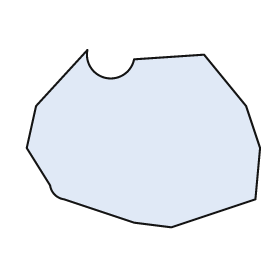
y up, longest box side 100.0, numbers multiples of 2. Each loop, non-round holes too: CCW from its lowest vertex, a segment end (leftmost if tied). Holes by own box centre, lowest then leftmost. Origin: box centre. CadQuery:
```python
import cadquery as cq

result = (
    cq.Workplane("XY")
    .moveTo(12.0, -38.0)
    .lineTo(48.0, -26.0)
    .lineTo(50.0, -4.0)
    .lineTo(44.0, 14.0)
    .lineTo(26.0, 36.0)
    .lineTo(-4.0, 34.0)
    .threePointArc((-16.0, 26.0), (-24.0, 38.0))
    .lineTo(-46.0, 14.0)
    .lineTo(-50.0, -4.0)
    .lineTo(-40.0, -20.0)
    .threePointArc((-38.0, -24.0), (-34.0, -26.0))
    .lineTo(-4.0, -36.0)
    .close()
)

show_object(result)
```